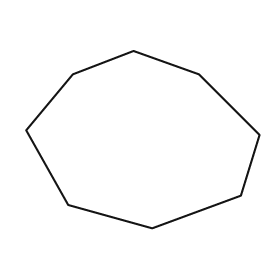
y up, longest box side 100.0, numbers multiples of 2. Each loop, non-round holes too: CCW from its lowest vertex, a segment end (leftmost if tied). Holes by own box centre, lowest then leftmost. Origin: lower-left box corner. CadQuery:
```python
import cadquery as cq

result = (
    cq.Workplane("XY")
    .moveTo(54.0, 0.0)
    .lineTo(92.0, 14.0)
    .lineTo(100.0, 40.0)
    .lineTo(74.0, 66.0)
    .lineTo(46.0, 76.0)
    .lineTo(20.0, 66.0)
    .lineTo(0.0, 42.0)
    .lineTo(18.0, 10.0)
    .close()
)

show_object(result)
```